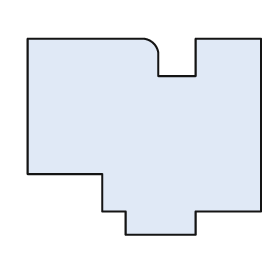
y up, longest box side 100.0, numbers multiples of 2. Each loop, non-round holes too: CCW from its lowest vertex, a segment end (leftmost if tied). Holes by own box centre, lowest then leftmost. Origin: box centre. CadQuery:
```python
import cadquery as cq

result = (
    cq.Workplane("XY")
    .moveTo(-8.0, -42.0)
    .lineTo(22.0, -42.0)
    .lineTo(22.0, -32.0)
    .lineTo(50.0, -32.0)
    .lineTo(50.0, 42.0)
    .lineTo(22.0, 42.0)
    .lineTo(22.0, 26.0)
    .lineTo(6.0, 26.0)
    .lineTo(6.0, 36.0)
    .threePointArc((4.0, 40.0), (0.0, 42.0))
    .lineTo(-50.0, 42.0)
    .lineTo(-50.0, -16.0)
    .lineTo(-18.0, -16.0)
    .lineTo(-18.0, -32.0)
    .lineTo(-8.0, -32.0)
    .close()
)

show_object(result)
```